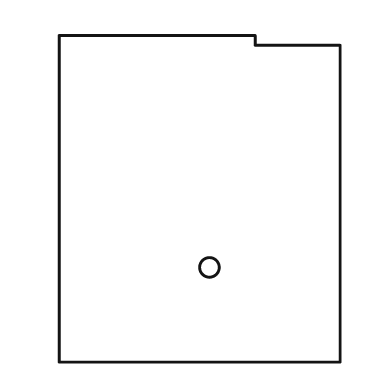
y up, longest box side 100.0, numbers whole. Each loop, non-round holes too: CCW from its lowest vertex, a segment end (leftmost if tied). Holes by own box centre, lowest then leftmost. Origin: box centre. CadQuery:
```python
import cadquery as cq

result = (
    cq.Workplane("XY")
    .moveTo(-43.0, -50.0)
    .lineTo(43.0, -50.0)
    .lineTo(43.0, 47.0)
    .lineTo(17.0, 47.0)
    .lineTo(17.0, 50.0)
    .lineTo(-43.0, 50.0)
    .close()
    .moveTo(3.0, -21.0)
    .circle(3.0)
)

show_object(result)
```